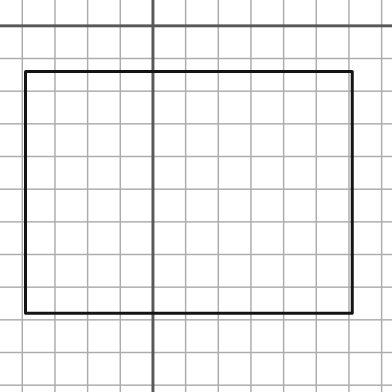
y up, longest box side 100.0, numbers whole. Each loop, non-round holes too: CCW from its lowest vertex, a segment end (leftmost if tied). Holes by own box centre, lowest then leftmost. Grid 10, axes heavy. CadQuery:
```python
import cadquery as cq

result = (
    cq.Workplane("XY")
    .moveTo(-39.0, -88.0)
    .lineTo(61.0, -88.0)
    .lineTo(61.0, -14.0)
    .lineTo(-39.0, -14.0)
    .close()
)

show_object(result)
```